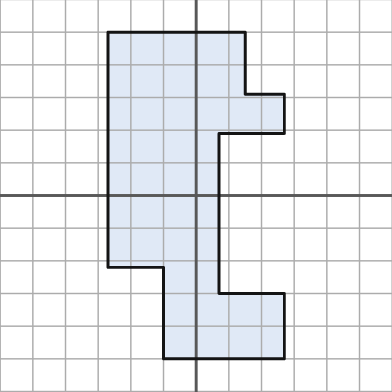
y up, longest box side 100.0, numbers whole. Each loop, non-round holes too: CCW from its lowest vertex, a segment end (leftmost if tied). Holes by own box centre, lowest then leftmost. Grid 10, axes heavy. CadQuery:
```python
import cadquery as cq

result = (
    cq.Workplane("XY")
    .moveTo(-10.0, -50.0)
    .lineTo(27.0, -50.0)
    .lineTo(27.0, -30.0)
    .lineTo(7.0, -30.0)
    .lineTo(7.0, 19.0)
    .lineTo(27.0, 19.0)
    .lineTo(27.0, 31.0)
    .lineTo(15.0, 31.0)
    .lineTo(15.0, 50.0)
    .lineTo(-27.0, 50.0)
    .lineTo(-27.0, -22.0)
    .lineTo(-10.0, -22.0)
    .close()
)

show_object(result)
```